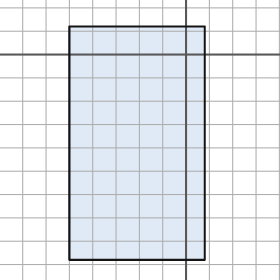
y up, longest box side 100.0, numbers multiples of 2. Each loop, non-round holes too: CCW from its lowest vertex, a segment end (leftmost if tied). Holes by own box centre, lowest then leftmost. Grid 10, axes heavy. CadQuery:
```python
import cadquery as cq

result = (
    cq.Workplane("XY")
    .moveTo(-50.0, -88.0)
    .lineTo(8.0, -88.0)
    .lineTo(8.0, 12.0)
    .lineTo(-50.0, 12.0)
    .close()
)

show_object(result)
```